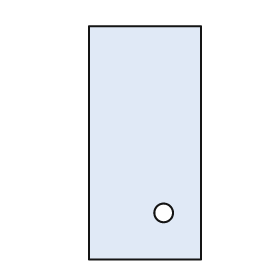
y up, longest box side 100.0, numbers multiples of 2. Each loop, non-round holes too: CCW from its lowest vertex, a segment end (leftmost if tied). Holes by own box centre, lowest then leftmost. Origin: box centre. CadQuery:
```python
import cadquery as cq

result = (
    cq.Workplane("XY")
    .moveTo(-24.0, -50.0)
    .lineTo(24.0, -50.0)
    .lineTo(24.0, 50.0)
    .lineTo(-24.0, 50.0)
    .close()
    .moveTo(8.0, -30.0)
    .circle(4.0)
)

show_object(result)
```